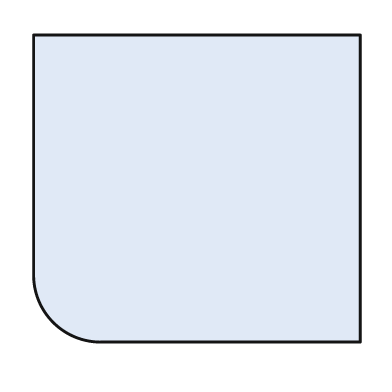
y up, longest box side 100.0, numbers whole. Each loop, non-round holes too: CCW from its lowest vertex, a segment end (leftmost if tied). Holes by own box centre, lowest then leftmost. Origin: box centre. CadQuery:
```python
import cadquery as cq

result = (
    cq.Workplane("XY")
    .moveTo(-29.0, -47.0)
    .lineTo(50.0, -47.0)
    .lineTo(50.0, 47.0)
    .lineTo(-50.0, 47.0)
    .lineTo(-50.0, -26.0)
    .threePointArc((-44.0, -41.0), (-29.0, -47.0))
    .close()
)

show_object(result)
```